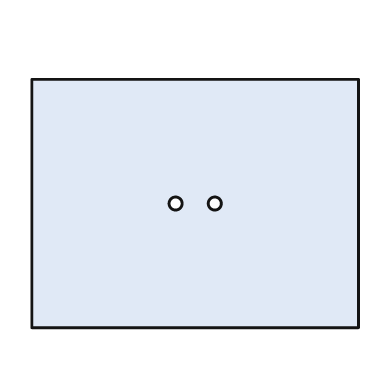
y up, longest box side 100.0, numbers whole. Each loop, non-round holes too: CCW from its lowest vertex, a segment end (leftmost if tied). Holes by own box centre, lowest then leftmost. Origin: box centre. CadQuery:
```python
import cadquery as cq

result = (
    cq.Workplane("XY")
    .moveTo(-50.0, -38.0)
    .lineTo(50.0, -38.0)
    .lineTo(50.0, 38.0)
    .lineTo(-50.0, 38.0)
    .close()
    .moveTo(-6.0, 0.0)
    .circle(2.0)
    .moveTo(6.0, 0.0)
    .circle(2.0)
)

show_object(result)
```